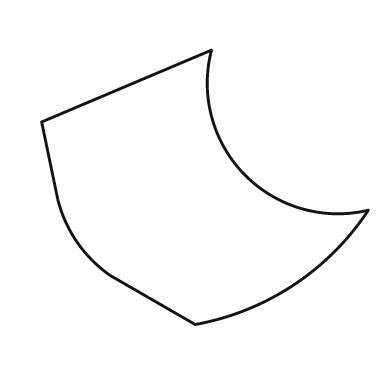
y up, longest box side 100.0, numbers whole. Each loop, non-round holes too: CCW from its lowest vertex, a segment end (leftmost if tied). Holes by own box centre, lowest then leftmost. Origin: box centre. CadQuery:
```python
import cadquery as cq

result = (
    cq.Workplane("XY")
    .moveTo(-3.0, -42.0)
    .threePointArc((27.0, -30.0), (50.0, -7.0))
    .threePointArc((12.0, 4.0), (2.0, 42.0))
    .lineTo(-50.0, 20.0)
    .lineTo(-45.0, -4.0)
    .threePointArc((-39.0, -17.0), (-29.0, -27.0))
    .close()
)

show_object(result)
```